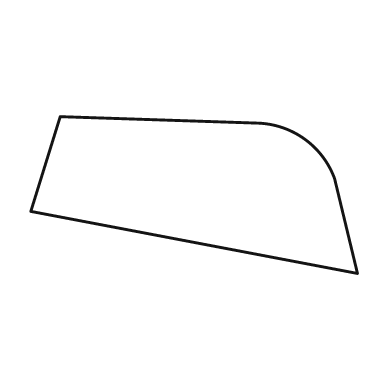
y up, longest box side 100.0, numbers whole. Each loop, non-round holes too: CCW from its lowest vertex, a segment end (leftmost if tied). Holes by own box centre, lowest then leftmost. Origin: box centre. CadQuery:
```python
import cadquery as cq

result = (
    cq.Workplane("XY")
    .moveTo(50.0, -24.0)
    .lineTo(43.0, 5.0)
    .threePointArc((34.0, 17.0), (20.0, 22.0))
    .lineTo(-41.0, 24.0)
    .lineTo(-50.0, -5.0)
    .close()
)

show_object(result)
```